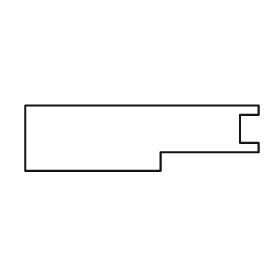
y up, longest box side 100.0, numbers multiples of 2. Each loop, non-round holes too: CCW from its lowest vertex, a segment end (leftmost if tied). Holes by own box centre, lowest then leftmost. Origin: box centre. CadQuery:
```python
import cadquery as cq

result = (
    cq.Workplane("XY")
    .moveTo(-50.0, -14.0)
    .lineTo(8.0, -14.0)
    .lineTo(8.0, -6.0)
    .lineTo(50.0, -6.0)
    .lineTo(50.0, -2.0)
    .lineTo(42.0, -2.0)
    .lineTo(42.0, 10.0)
    .lineTo(50.0, 10.0)
    .lineTo(50.0, 14.0)
    .lineTo(-50.0, 14.0)
    .close()
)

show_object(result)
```